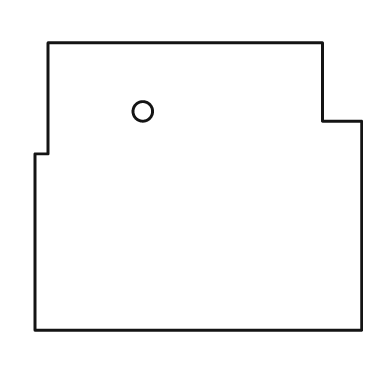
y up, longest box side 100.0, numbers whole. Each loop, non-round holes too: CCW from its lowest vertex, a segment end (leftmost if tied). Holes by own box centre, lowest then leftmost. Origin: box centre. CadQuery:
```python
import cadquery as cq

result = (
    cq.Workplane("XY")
    .moveTo(-50.0, -44.0)
    .lineTo(50.0, -44.0)
    .lineTo(50.0, 20.0)
    .lineTo(38.0, 20.0)
    .lineTo(38.0, 44.0)
    .lineTo(-46.0, 44.0)
    .lineTo(-46.0, 10.0)
    .lineTo(-50.0, 10.0)
    .close()
    .moveTo(-17.0, 23.0)
    .circle(3.0)
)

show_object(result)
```